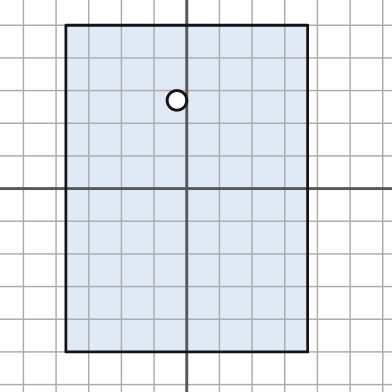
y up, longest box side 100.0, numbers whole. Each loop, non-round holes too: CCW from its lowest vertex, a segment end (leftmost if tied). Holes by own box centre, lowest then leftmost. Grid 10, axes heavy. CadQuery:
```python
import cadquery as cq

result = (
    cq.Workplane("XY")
    .moveTo(-37.0, -50.0)
    .lineTo(37.0, -50.0)
    .lineTo(37.0, 50.0)
    .lineTo(-37.0, 50.0)
    .close()
    .moveTo(-3.0, 27.0)
    .circle(3.0)
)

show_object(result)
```